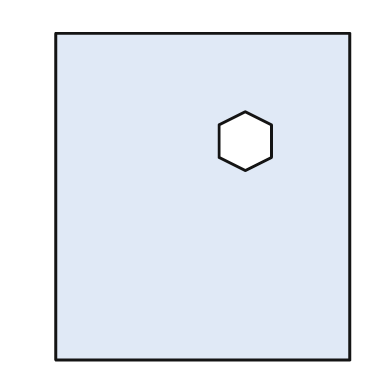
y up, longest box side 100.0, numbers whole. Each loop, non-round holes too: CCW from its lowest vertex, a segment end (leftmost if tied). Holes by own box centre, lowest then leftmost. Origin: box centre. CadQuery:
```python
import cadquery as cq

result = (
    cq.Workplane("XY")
    .moveTo(-45.0, -50.0)
    .lineTo(45.0, -50.0)
    .lineTo(45.0, 50.0)
    .lineTo(-45.0, 50.0)
    .close()
    .moveTo(13.0, 8.0)
    .lineTo(21.0, 12.0)
    .lineTo(21.0, 22.0)
    .lineTo(13.0, 26.0)
    .lineTo(5.0, 22.0)
    .lineTo(5.0, 12.0)
    .close()
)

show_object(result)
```